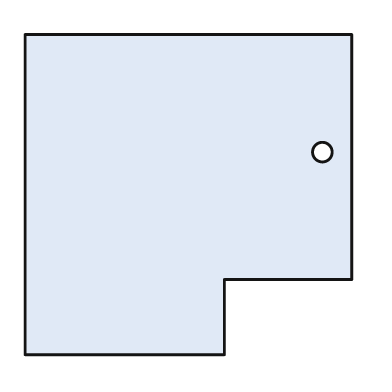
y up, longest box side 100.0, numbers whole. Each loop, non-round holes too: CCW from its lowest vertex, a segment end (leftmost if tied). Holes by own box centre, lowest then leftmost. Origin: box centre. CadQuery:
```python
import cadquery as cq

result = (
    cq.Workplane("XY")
    .moveTo(-50.0, -49.0)
    .lineTo(11.0, -49.0)
    .lineTo(11.0, -26.0)
    .lineTo(50.0, -26.0)
    .lineTo(50.0, 49.0)
    .lineTo(-50.0, 49.0)
    .close()
    .moveTo(41.0, 13.0)
    .circle(3.0)
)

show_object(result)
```